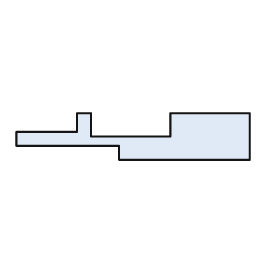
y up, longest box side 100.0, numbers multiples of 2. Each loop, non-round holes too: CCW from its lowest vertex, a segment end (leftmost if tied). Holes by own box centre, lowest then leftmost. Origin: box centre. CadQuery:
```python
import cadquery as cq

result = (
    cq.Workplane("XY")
    .moveTo(-6.0, -10.0)
    .lineTo(50.0, -10.0)
    .lineTo(50.0, 10.0)
    .lineTo(16.0, 10.0)
    .lineTo(16.0, 0.0)
    .lineTo(-18.0, 0.0)
    .lineTo(-18.0, 10.0)
    .lineTo(-24.0, 10.0)
    .lineTo(-24.0, 2.0)
    .lineTo(-50.0, 2.0)
    .lineTo(-50.0, -4.0)
    .lineTo(-6.0, -4.0)
    .close()
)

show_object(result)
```